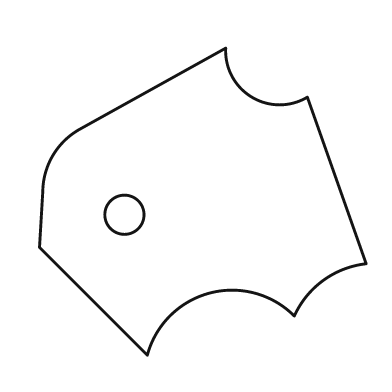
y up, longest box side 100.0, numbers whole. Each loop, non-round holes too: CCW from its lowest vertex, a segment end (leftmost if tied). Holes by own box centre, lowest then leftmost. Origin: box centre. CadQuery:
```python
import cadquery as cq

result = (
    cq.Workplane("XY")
    .moveTo(-17.0, -47.0)
    .threePointArc((2.0, -28.0), (28.0, -35.0))
    .threePointArc((37.0, -24.0), (50.0, -19.0))
    .lineTo(32.0, 32.0)
    .threePointArc((15.0, 32.0), (7.0, 47.0))
    .lineTo(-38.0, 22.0)
    .threePointArc((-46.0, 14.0), (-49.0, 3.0))
    .lineTo(-50.0, -14.0)
    .close()
    .moveTo(-24.0, -4.0)
    .circle(6.0)
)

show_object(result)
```